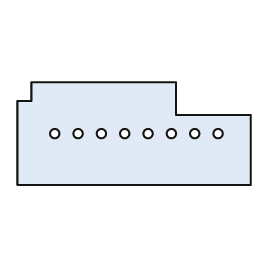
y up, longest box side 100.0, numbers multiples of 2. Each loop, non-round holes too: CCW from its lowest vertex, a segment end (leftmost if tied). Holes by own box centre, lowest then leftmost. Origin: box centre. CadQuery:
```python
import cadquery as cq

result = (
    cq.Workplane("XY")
    .moveTo(-50.0, -22.0)
    .lineTo(50.0, -22.0)
    .lineTo(50.0, 8.0)
    .lineTo(18.0, 8.0)
    .lineTo(18.0, 22.0)
    .lineTo(-44.0, 22.0)
    .lineTo(-44.0, 14.0)
    .lineTo(-50.0, 14.0)
    .close()
    .moveTo(-34.0, 0.0)
    .circle(2.0)
    .moveTo(-24.0, 0.0)
    .circle(2.0)
    .moveTo(-14.0, 0.0)
    .circle(2.0)
    .moveTo(-4.0, 0.0)
    .circle(2.0)
    .moveTo(6.0, 0.0)
    .circle(2.0)
    .moveTo(16.0, 0.0)
    .circle(2.0)
    .moveTo(26.0, 0.0)
    .circle(2.0)
    .moveTo(36.0, 0.0)
    .circle(2.0)
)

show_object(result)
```